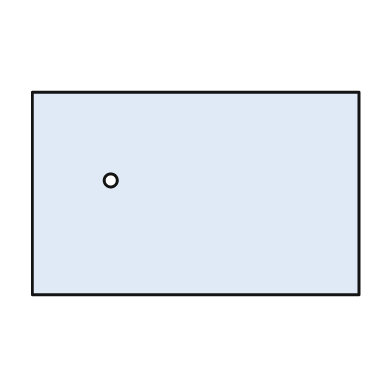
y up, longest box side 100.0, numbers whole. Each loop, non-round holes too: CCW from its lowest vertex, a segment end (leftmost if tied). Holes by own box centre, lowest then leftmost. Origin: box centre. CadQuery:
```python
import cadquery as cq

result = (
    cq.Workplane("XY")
    .moveTo(-50.0, -31.0)
    .lineTo(50.0, -31.0)
    .lineTo(50.0, 31.0)
    .lineTo(-50.0, 31.0)
    .close()
    .moveTo(-26.0, 4.0)
    .circle(2.0)
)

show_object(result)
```